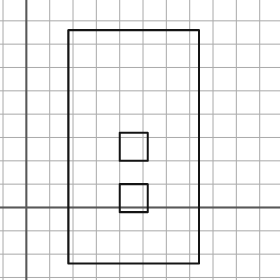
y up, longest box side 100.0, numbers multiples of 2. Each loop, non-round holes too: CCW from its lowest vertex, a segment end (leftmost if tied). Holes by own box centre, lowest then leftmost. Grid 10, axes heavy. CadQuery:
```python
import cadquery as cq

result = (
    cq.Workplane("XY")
    .moveTo(18.0, -24.0)
    .lineTo(74.0, -24.0)
    .lineTo(74.0, 76.0)
    .lineTo(18.0, 76.0)
    .close()
    .moveTo(40.0, -2.0)
    .lineTo(52.0, -2.0)
    .lineTo(52.0, 10.0)
    .lineTo(40.0, 10.0)
    .close()
    .moveTo(40.0, 20.0)
    .lineTo(52.0, 20.0)
    .lineTo(52.0, 32.0)
    .lineTo(40.0, 32.0)
    .close()
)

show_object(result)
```